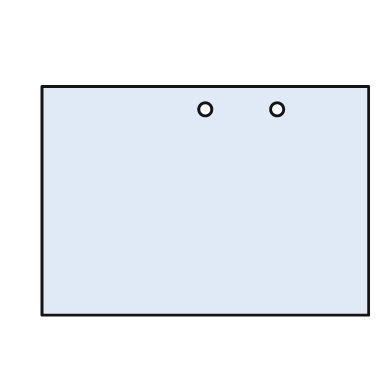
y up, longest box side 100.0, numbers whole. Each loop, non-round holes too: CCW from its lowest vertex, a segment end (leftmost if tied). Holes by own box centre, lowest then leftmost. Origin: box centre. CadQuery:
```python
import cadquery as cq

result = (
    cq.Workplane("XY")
    .moveTo(-50.0, -35.0)
    .lineTo(50.0, -35.0)
    .lineTo(50.0, 35.0)
    .lineTo(-50.0, 35.0)
    .close()
    .moveTo(0.0, 28.0)
    .circle(2.0)
    .moveTo(22.0, 28.0)
    .circle(2.0)
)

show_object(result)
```